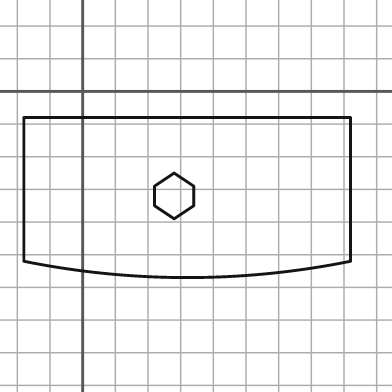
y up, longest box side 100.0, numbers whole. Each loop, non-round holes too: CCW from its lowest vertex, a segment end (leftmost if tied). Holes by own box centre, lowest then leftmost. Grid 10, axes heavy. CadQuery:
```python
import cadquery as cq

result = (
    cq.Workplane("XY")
    .moveTo(-18.0, -52.0)
    .threePointArc((32.0, -57.0), (82.0, -52.0))
    .lineTo(82.0, -8.0)
    .lineTo(-18.0, -8.0)
    .close()
    .moveTo(28.0, -39.0)
    .lineTo(34.0, -35.0)
    .lineTo(34.0, -29.0)
    .lineTo(28.0, -25.0)
    .lineTo(22.0, -29.0)
    .lineTo(22.0, -35.0)
    .close()
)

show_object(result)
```